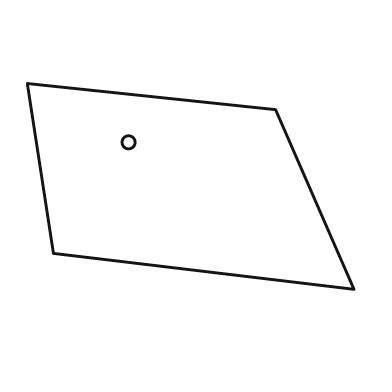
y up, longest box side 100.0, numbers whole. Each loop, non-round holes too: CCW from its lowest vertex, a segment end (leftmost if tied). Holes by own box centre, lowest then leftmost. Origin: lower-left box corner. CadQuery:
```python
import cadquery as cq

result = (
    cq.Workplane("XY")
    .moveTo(100.0, 0.0)
    .lineTo(76.0, 55.0)
    .lineTo(0.0, 63.0)
    .lineTo(8.0, 11.0)
    .close()
    .moveTo(31.0, 45.0)
    .circle(2.0)
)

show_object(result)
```